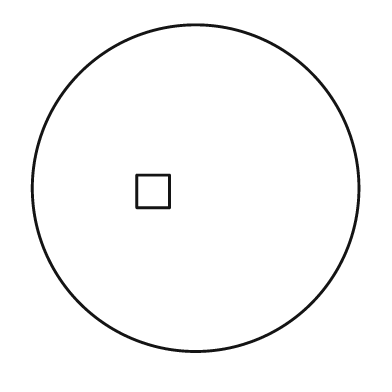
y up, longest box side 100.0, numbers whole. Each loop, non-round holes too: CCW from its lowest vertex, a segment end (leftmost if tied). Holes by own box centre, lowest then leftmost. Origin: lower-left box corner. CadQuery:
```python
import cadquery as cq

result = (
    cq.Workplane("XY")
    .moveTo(50.0, 50.0)
    .circle(50.0)
    .moveTo(32.0, 44.0)
    .lineTo(42.0, 44.0)
    .lineTo(42.0, 54.0)
    .lineTo(32.0, 54.0)
    .close()
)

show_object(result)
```